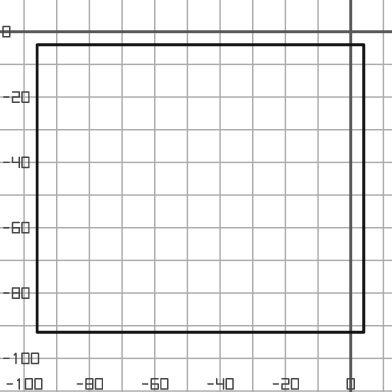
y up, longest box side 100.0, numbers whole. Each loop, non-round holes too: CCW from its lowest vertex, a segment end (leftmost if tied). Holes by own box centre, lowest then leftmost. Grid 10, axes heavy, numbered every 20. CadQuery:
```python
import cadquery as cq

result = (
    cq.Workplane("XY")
    .moveTo(-96.0, -92.0)
    .lineTo(4.0, -92.0)
    .lineTo(4.0, -4.0)
    .lineTo(-96.0, -4.0)
    .close()
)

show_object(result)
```